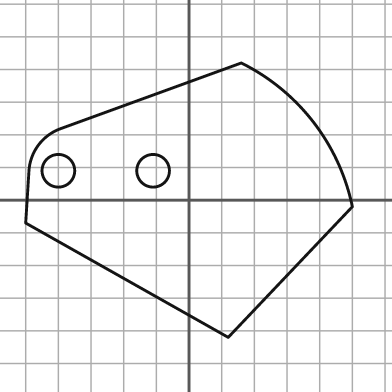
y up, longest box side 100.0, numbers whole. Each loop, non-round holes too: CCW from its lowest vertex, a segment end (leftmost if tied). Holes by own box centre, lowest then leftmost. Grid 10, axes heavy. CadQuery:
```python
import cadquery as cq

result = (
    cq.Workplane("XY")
    .moveTo(12.0, -42.0)
    .lineTo(50.0, -2.0)
    .threePointArc((38.0, 24.0), (16.0, 42.0))
    .lineTo(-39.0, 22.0)
    .threePointArc((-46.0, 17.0), (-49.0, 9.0))
    .lineTo(-50.0, -7.0)
    .close()
    .moveTo(-40.0, 9.0)
    .circle(5.0)
    .moveTo(-11.0, 9.0)
    .circle(5.0)
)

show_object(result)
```